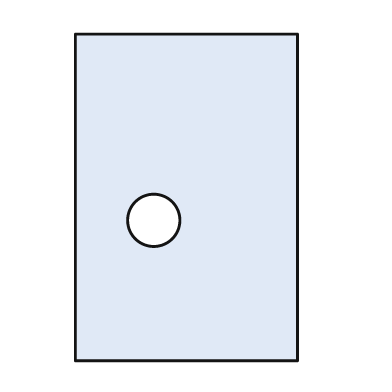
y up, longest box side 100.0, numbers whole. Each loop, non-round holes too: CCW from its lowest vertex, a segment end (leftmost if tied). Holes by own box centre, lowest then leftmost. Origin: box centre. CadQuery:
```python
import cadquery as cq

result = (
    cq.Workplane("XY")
    .moveTo(-34.0, -50.0)
    .lineTo(34.0, -50.0)
    .lineTo(34.0, 50.0)
    .lineTo(-34.0, 50.0)
    .close()
    .moveTo(-10.0, -7.0)
    .circle(8.0)
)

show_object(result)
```